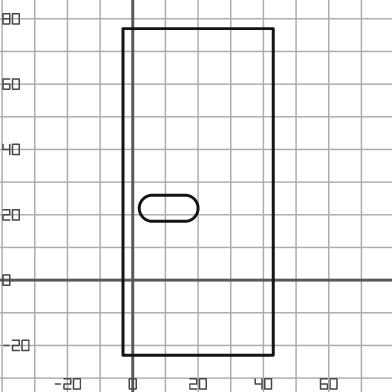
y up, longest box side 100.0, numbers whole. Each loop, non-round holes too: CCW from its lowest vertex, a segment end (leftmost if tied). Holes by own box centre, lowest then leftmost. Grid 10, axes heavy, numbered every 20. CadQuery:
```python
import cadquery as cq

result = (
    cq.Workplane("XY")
    .moveTo(-3.0, -23.0)
    .lineTo(43.0, -23.0)
    .lineTo(43.0, 77.0)
    .lineTo(-3.0, 77.0)
    .close()
    .moveTo(6.0, 18.0)
    .lineTo(16.0, 18.0)
    .threePointArc((20.0, 22.0), (16.0, 26.0))
    .lineTo(6.0, 26.0)
    .threePointArc((2.0, 22.0), (6.0, 18.0))
    .close()
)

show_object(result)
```